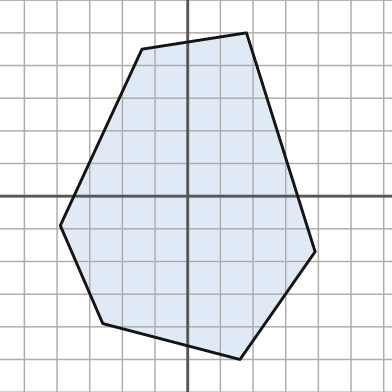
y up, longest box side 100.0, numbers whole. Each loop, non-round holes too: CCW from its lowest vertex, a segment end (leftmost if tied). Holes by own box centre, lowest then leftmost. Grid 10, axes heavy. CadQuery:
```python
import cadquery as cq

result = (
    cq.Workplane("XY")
    .moveTo(16.0, -50.0)
    .lineTo(39.0, -17.0)
    .lineTo(18.0, 50.0)
    .lineTo(-14.0, 45.0)
    .lineTo(-39.0, -9.0)
    .lineTo(-26.0, -39.0)
    .close()
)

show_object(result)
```